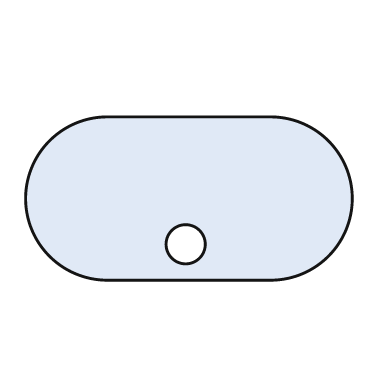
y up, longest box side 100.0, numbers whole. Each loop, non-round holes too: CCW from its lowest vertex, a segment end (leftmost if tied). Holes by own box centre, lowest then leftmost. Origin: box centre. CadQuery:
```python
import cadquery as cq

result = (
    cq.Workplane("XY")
    .moveTo(-25.0, -25.0)
    .lineTo(25.0, -25.0)
    .threePointArc((50.0, 0.0), (25.0, 25.0))
    .lineTo(-25.0, 25.0)
    .threePointArc((-50.0, 0.0), (-25.0, -25.0))
    .close()
    .moveTo(-1.0, -14.0)
    .circle(6.0)
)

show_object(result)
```